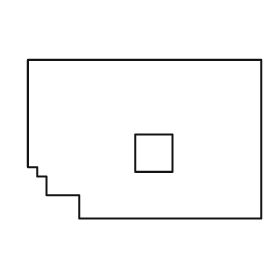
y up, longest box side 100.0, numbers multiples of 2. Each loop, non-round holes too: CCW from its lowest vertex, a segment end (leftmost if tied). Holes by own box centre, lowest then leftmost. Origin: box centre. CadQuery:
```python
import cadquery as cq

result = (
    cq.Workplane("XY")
    .moveTo(-28.0, -34.0)
    .lineTo(50.0, -34.0)
    .lineTo(50.0, 34.0)
    .lineTo(-50.0, 34.0)
    .lineTo(-50.0, -12.0)
    .lineTo(-46.0, -12.0)
    .lineTo(-46.0, -16.0)
    .lineTo(-42.0, -16.0)
    .lineTo(-42.0, -24.0)
    .lineTo(-28.0, -24.0)
    .close()
    .moveTo(-4.0, -14.0)
    .lineTo(12.0, -14.0)
    .lineTo(12.0, 2.0)
    .lineTo(-4.0, 2.0)
    .close()
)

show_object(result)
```